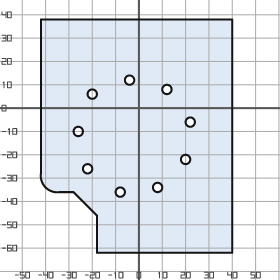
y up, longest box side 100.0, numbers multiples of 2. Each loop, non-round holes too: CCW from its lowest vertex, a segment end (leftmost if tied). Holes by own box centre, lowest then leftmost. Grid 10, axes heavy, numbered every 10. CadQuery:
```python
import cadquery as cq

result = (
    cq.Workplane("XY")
    .moveTo(-18.0, -62.0)
    .lineTo(40.0, -62.0)
    .lineTo(40.0, 38.0)
    .lineTo(-42.0, 38.0)
    .lineTo(-42.0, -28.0)
    .threePointArc((-40.0, -34.0), (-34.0, -36.0))
    .lineTo(-28.0, -36.0)
    .lineTo(-18.0, -46.0)
    .close()
    .moveTo(-8.0, -36.0)
    .circle(2.0)
    .moveTo(8.0, -34.0)
    .circle(2.0)
    .moveTo(-22.0, -26.0)
    .circle(2.0)
    .moveTo(20.0, -22.0)
    .circle(2.0)
    .moveTo(-26.0, -10.0)
    .circle(2.0)
    .moveTo(22.0, -6.0)
    .circle(2.0)
    .moveTo(-20.0, 6.0)
    .circle(2.0)
    .moveTo(12.0, 8.0)
    .circle(2.0)
    .moveTo(-4.0, 12.0)
    .circle(2.0)
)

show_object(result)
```